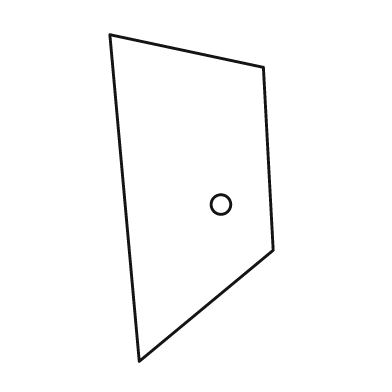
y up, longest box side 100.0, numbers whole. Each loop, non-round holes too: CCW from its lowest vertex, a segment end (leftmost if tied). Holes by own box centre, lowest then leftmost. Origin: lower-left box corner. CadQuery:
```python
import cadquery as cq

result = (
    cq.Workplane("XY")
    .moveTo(9.0, 0.0)
    .lineTo(50.0, 34.0)
    .lineTo(47.0, 90.0)
    .lineTo(0.0, 100.0)
    .close()
    .moveTo(34.0, 48.0)
    .circle(3.0)
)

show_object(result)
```